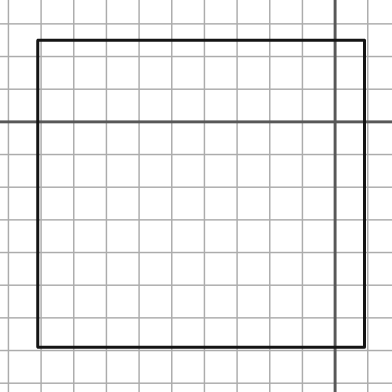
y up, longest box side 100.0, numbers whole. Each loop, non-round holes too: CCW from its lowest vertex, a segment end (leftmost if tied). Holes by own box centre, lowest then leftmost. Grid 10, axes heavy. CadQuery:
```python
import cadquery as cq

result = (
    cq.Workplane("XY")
    .moveTo(-91.0, -69.0)
    .lineTo(9.0, -69.0)
    .lineTo(9.0, 25.0)
    .lineTo(-91.0, 25.0)
    .close()
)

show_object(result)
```